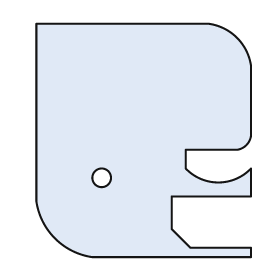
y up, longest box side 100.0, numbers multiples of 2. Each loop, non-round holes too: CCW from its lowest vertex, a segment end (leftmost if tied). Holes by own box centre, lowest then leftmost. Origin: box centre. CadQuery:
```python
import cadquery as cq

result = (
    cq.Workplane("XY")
    .moveTo(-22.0, -50.0)
    .lineTo(46.0, -50.0)
    .lineTo(46.0, -46.0)
    .lineTo(20.0, -46.0)
    .lineTo(12.0, -38.0)
    .lineTo(12.0, -24.0)
    .lineTo(46.0, -24.0)
    .lineTo(46.0, -12.0)
    .threePointArc((32.0, -18.0), (18.0, -12.0))
    .lineTo(18.0, -4.0)
    .lineTo(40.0, -4.0)
    .threePointArc((44.0, -2.0), (46.0, 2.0))
    .lineTo(46.0, 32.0)
    .threePointArc((40.0, 44.0), (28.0, 50.0))
    .lineTo(-46.0, 50.0)
    .lineTo(-46.0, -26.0)
    .threePointArc((-38.0, -42.0), (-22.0, -50.0))
    .close()
    .moveTo(-18.0, -16.0)
    .circle(4.0)
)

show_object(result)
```